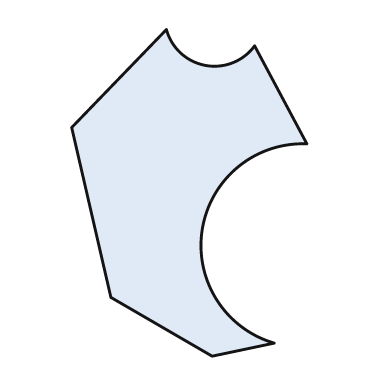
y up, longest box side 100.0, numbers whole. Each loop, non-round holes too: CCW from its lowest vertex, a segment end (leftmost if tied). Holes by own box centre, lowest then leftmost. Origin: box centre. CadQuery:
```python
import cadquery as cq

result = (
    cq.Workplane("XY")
    .moveTo(7.0, -50.0)
    .lineTo(26.0, -46.0)
    .threePointArc((4.0, -11.0), (36.0, 15.0))
    .lineTo(20.0, 45.0)
    .threePointArc((5.0, 39.0), (-7.0, 50.0))
    .lineTo(-36.0, 20.0)
    .lineTo(-24.0, -32.0)
    .close()
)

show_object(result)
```